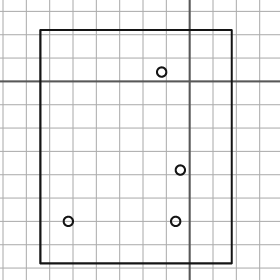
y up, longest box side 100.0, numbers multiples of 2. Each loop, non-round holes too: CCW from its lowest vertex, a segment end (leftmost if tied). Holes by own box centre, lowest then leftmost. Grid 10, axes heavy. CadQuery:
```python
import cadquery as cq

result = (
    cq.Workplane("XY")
    .moveTo(-64.0, -78.0)
    .lineTo(18.0, -78.0)
    .lineTo(18.0, 22.0)
    .lineTo(-64.0, 22.0)
    .close()
    .moveTo(-52.0, -60.0)
    .circle(2.0)
    .moveTo(-6.0, -60.0)
    .circle(2.0)
    .moveTo(-4.0, -38.0)
    .circle(2.0)
    .moveTo(-12.0, 4.0)
    .circle(2.0)
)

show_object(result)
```